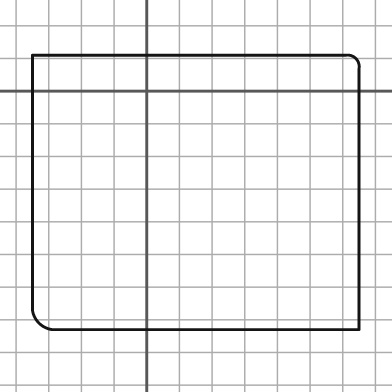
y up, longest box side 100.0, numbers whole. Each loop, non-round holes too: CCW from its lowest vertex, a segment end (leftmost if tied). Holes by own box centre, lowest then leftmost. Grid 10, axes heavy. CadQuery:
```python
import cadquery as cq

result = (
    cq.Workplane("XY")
    .moveTo(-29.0, -73.0)
    .lineTo(65.0, -73.0)
    .lineTo(65.0, 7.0)
    .threePointArc((64.0, 10.0), (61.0, 11.0))
    .lineTo(-35.0, 11.0)
    .lineTo(-35.0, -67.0)
    .threePointArc((-33.0, -71.0), (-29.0, -73.0))
    .close()
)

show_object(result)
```